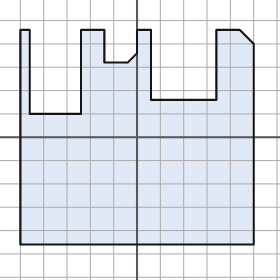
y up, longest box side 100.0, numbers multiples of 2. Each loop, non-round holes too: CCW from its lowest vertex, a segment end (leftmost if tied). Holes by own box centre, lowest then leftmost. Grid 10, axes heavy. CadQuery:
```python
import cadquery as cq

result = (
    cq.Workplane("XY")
    .moveTo(-50.0, -46.0)
    .lineTo(50.0, -46.0)
    .lineTo(50.0, 40.0)
    .lineTo(44.0, 46.0)
    .lineTo(34.0, 46.0)
    .lineTo(34.0, 16.0)
    .lineTo(6.0, 16.0)
    .lineTo(6.0, 46.0)
    .lineTo(0.0, 46.0)
    .lineTo(0.0, 36.0)
    .lineTo(-4.0, 32.0)
    .lineTo(-14.0, 32.0)
    .lineTo(-14.0, 46.0)
    .lineTo(-24.0, 46.0)
    .lineTo(-24.0, 10.0)
    .lineTo(-46.0, 10.0)
    .lineTo(-46.0, 46.0)
    .lineTo(-50.0, 46.0)
    .close()
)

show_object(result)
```